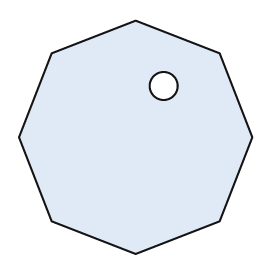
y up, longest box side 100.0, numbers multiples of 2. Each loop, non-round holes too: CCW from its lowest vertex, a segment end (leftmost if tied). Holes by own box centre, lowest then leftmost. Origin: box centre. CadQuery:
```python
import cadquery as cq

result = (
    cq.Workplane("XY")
    .moveTo(0.0, -50.0)
    .lineTo(36.0, -36.0)
    .lineTo(50.0, 0.0)
    .lineTo(36.0, 36.0)
    .lineTo(0.0, 50.0)
    .lineTo(-36.0, 36.0)
    .lineTo(-50.0, 0.0)
    .lineTo(-36.0, -36.0)
    .close()
    .moveTo(12.0, 22.0)
    .circle(6.0)
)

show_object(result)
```